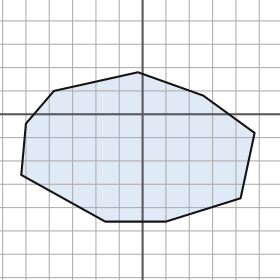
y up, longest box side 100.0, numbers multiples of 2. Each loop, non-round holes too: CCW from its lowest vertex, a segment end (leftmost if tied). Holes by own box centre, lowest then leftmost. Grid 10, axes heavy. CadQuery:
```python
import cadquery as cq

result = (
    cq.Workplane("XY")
    .moveTo(-16.0, -46.0)
    .lineTo(10.0, -46.0)
    .lineTo(42.0, -36.0)
    .lineTo(48.0, -8.0)
    .lineTo(26.0, 8.0)
    .lineTo(-2.0, 18.0)
    .lineTo(-38.0, 10.0)
    .lineTo(-50.0, -4.0)
    .lineTo(-52.0, -26.0)
    .close()
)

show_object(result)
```